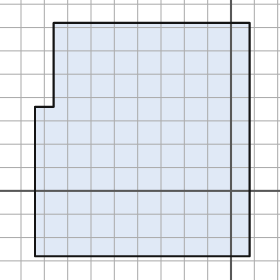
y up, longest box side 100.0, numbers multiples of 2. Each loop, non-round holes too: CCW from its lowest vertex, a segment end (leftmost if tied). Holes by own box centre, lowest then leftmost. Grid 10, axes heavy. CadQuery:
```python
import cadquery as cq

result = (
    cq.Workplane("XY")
    .moveTo(-84.0, -28.0)
    .lineTo(8.0, -28.0)
    .lineTo(8.0, 72.0)
    .lineTo(-76.0, 72.0)
    .lineTo(-76.0, 36.0)
    .lineTo(-84.0, 36.0)
    .close()
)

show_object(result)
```